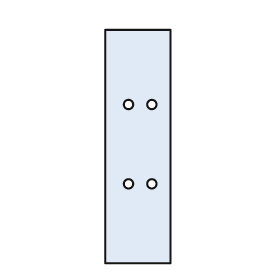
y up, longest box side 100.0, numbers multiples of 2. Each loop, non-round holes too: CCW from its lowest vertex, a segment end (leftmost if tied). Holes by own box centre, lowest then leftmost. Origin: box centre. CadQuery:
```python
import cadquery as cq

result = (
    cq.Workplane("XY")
    .moveTo(-14.0, -50.0)
    .lineTo(14.0, -50.0)
    .lineTo(14.0, 50.0)
    .lineTo(-14.0, 50.0)
    .close()
    .moveTo(-4.0, -16.0)
    .circle(2.0)
    .moveTo(6.0, -16.0)
    .circle(2.0)
    .moveTo(-4.0, 18.0)
    .circle(2.0)
    .moveTo(6.0, 18.0)
    .circle(2.0)
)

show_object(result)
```